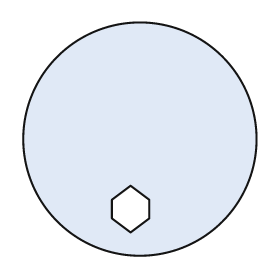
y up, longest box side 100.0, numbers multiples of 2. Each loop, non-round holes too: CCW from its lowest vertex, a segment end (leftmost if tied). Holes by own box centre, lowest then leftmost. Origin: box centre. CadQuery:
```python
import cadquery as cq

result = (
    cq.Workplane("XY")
    .moveTo(0.0, 0.0)
    .circle(50.0)
    .moveTo(-4.0, -40.0)
    .lineTo(4.0, -34.0)
    .lineTo(4.0, -26.0)
    .lineTo(-4.0, -20.0)
    .lineTo(-12.0, -26.0)
    .lineTo(-12.0, -34.0)
    .close()
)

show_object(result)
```